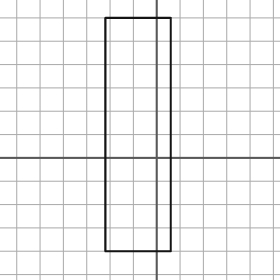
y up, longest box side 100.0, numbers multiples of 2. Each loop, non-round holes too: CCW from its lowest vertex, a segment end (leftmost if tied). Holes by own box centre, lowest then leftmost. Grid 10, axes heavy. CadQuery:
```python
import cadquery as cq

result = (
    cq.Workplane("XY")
    .moveTo(-22.0, -40.0)
    .lineTo(6.0, -40.0)
    .lineTo(6.0, 60.0)
    .lineTo(-22.0, 60.0)
    .close()
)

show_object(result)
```